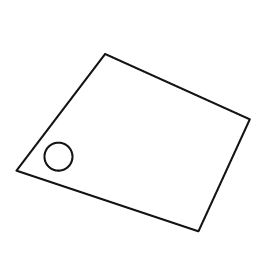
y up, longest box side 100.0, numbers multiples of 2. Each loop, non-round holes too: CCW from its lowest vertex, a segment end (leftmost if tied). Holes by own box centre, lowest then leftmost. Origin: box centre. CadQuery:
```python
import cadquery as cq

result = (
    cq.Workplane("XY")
    .moveTo(28.0, -38.0)
    .lineTo(50.0, 10.0)
    .lineTo(-12.0, 38.0)
    .lineTo(-50.0, -12.0)
    .close()
    .moveTo(-32.0, -6.0)
    .circle(6.0)
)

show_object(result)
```